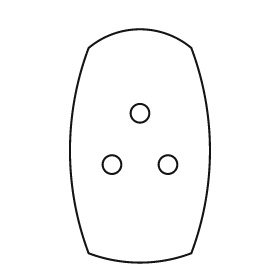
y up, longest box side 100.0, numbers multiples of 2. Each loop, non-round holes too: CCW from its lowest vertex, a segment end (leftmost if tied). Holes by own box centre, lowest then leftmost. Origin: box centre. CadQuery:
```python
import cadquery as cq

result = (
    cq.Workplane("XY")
    .moveTo(-22.0, -46.0)
    .threePointArc((0.0, -50.0), (22.0, -46.0))
    .threePointArc((30.0, -2.0), (22.0, 42.0))
    .threePointArc((0.0, 50.0), (-22.0, 42.0))
    .threePointArc((-30.0, -2.0), (-22.0, -46.0))
    .close()
    .moveTo(-12.0, -8.0)
    .circle(4.0)
    .moveTo(12.0, -8.0)
    .circle(4.0)
    .moveTo(0.0, 14.0)
    .circle(4.0)
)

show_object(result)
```